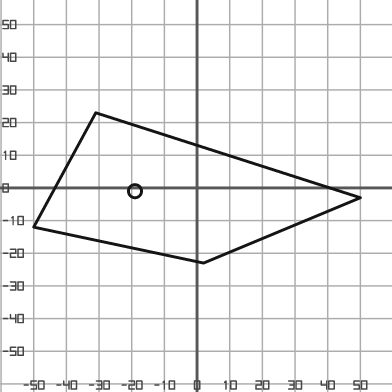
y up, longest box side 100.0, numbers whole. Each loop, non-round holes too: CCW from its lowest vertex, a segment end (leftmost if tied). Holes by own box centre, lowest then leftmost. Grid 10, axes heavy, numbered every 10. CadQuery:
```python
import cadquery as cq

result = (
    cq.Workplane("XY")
    .moveTo(2.0, -23.0)
    .lineTo(50.0, -3.0)
    .lineTo(-31.0, 23.0)
    .lineTo(-50.0, -12.0)
    .close()
    .moveTo(-19.0, -1.0)
    .circle(2.0)
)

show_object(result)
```